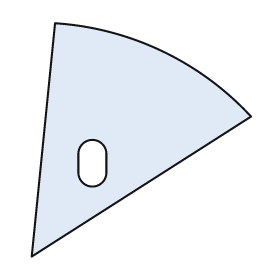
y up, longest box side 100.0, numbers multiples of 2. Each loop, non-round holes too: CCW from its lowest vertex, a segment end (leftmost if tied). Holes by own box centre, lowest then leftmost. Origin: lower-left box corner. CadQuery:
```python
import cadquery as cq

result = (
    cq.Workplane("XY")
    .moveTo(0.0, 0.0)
    .lineTo(94.0, 60.0)
    .threePointArc((56.0, 88.0), (10.0, 100.0))
    .close()
    .moveTo(20.0, 36.0)
    .threePointArc((26.0, 30.0), (32.0, 36.0))
    .lineTo(32.0, 44.0)
    .threePointArc((26.0, 50.0), (20.0, 44.0))
    .close()
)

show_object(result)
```